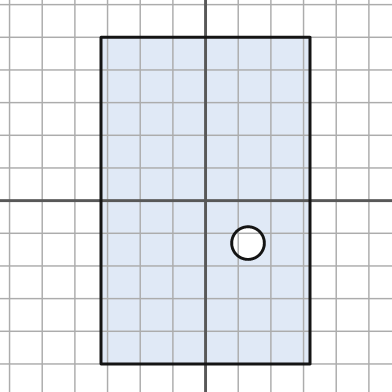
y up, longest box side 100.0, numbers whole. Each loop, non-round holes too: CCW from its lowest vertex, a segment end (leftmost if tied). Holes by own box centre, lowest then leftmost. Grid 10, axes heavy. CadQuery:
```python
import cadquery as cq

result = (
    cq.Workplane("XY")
    .moveTo(-32.0, -50.0)
    .lineTo(32.0, -50.0)
    .lineTo(32.0, 50.0)
    .lineTo(-32.0, 50.0)
    .close()
    .moveTo(13.0, -13.0)
    .circle(5.0)
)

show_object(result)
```